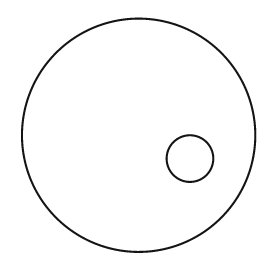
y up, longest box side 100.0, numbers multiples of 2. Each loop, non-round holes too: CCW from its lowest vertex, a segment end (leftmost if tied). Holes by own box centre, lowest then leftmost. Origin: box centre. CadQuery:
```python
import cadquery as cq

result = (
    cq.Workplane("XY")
    .moveTo(0.0, 0.0)
    .circle(50.0)
    .moveTo(22.0, -10.0)
    .circle(10.0)
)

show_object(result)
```